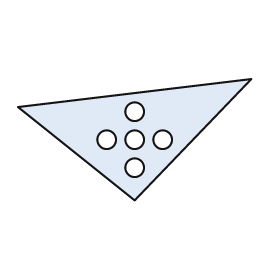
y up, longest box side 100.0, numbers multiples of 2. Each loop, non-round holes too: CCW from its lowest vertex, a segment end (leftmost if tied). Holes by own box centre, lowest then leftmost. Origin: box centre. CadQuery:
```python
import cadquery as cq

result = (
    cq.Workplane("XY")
    .moveTo(0.0, -26.0)
    .lineTo(50.0, 26.0)
    .lineTo(-50.0, 14.0)
    .close()
    .moveTo(0.0, -12.0)
    .circle(4.0)
    .moveTo(-12.0, 0.0)
    .circle(4.0)
    .moveTo(0.0, 0.0)
    .circle(4.0)
    .moveTo(12.0, 0.0)
    .circle(4.0)
    .moveTo(0.0, 12.0)
    .circle(4.0)
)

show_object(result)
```